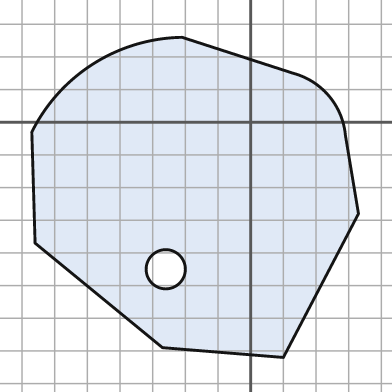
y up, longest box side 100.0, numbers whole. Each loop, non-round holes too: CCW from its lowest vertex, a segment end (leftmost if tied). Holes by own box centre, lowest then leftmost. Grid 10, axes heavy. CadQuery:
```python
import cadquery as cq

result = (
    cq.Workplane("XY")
    .moveTo(10.0, -72.0)
    .lineTo(33.0, -28.0)
    .lineTo(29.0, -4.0)
    .threePointArc((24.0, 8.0), (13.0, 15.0))
    .lineTo(-21.0, 26.0)
    .threePointArc((-48.0, 18.0), (-67.0, -3.0))
    .lineTo(-66.0, -37.0)
    .lineTo(-27.0, -69.0)
    .close()
    .moveTo(-26.0, -45.0)
    .circle(6.0)
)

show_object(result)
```